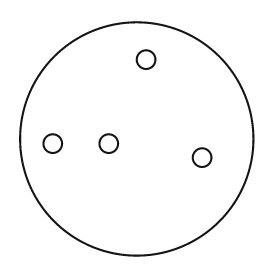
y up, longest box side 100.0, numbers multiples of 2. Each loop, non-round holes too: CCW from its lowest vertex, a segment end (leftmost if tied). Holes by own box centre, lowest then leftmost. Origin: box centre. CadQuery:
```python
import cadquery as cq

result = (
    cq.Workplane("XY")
    .moveTo(0.0, 0.0)
    .circle(50.0)
    .moveTo(28.0, -8.0)
    .circle(4.0)
    .moveTo(-36.0, -2.0)
    .circle(4.0)
    .moveTo(-12.0, -2.0)
    .circle(4.0)
    .moveTo(4.0, 34.0)
    .circle(4.0)
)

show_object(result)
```